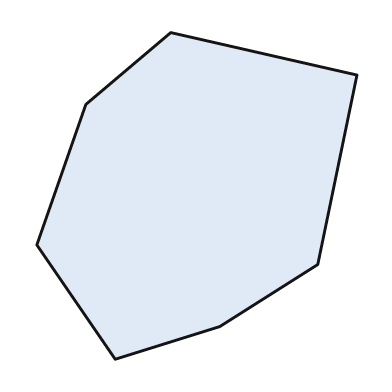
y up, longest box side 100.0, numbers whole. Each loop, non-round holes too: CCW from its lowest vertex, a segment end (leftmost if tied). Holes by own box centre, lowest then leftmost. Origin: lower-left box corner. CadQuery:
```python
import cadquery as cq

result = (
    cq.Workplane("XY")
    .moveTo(24.0, 0.0)
    .lineTo(56.0, 10.0)
    .lineTo(86.0, 29.0)
    .lineTo(98.0, 87.0)
    .lineTo(41.0, 100.0)
    .lineTo(15.0, 78.0)
    .lineTo(0.0, 35.0)
    .close()
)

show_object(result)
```